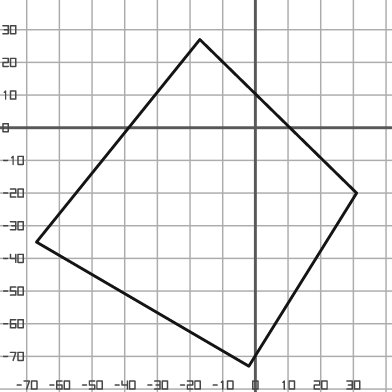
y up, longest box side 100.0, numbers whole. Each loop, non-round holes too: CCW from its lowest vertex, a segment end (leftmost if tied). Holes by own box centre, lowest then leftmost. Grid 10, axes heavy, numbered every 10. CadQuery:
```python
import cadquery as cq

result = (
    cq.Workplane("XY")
    .moveTo(-2.0, -73.0)
    .lineTo(31.0, -20.0)
    .lineTo(-17.0, 27.0)
    .lineTo(-67.0, -35.0)
    .close()
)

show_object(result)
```